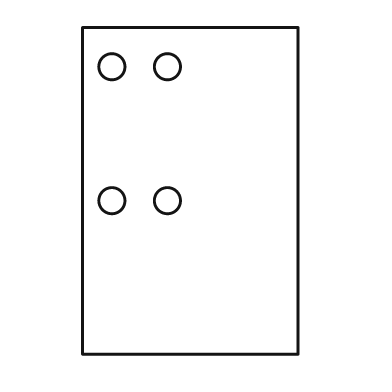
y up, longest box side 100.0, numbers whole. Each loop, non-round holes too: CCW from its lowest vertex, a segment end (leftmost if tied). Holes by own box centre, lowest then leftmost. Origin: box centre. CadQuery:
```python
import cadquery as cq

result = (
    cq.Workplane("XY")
    .moveTo(-33.0, -50.0)
    .lineTo(33.0, -50.0)
    .lineTo(33.0, 50.0)
    .lineTo(-33.0, 50.0)
    .close()
    .moveTo(-24.0, -3.0)
    .circle(4.0)
    .moveTo(-7.0, -3.0)
    .circle(4.0)
    .moveTo(-24.0, 38.0)
    .circle(4.0)
    .moveTo(-7.0, 38.0)
    .circle(4.0)
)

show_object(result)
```